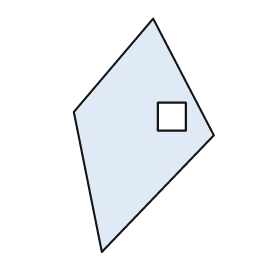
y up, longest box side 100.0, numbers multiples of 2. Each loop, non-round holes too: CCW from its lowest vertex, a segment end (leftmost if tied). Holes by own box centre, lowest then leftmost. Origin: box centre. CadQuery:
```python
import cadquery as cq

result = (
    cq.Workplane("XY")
    .moveTo(-18.0, -50.0)
    .lineTo(30.0, 0.0)
    .lineTo(4.0, 50.0)
    .lineTo(-30.0, 10.0)
    .close()
    .moveTo(6.0, 2.0)
    .lineTo(18.0, 2.0)
    .lineTo(18.0, 14.0)
    .lineTo(6.0, 14.0)
    .close()
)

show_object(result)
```